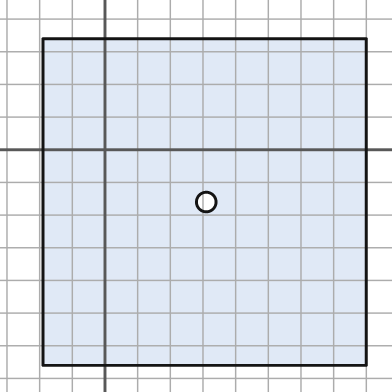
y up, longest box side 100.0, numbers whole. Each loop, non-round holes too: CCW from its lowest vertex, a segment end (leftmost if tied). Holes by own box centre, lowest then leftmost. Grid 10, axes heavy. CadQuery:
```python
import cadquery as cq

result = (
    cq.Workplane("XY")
    .moveTo(-19.0, -66.0)
    .lineTo(80.0, -66.0)
    .lineTo(80.0, 34.0)
    .lineTo(-19.0, 34.0)
    .close()
    .moveTo(31.0, -16.0)
    .circle(3.0)
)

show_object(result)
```